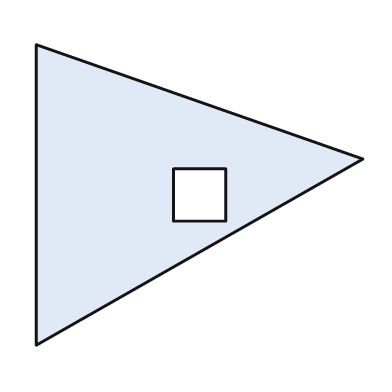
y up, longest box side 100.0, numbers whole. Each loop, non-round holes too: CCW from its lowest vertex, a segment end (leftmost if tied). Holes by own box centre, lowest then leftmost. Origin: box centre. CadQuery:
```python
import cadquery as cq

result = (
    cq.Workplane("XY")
    .moveTo(-50.0, -46.0)
    .lineTo(50.0, 11.0)
    .lineTo(-50.0, 46.0)
    .close()
    .moveTo(-8.0, -8.0)
    .lineTo(8.0, -8.0)
    .lineTo(8.0, 8.0)
    .lineTo(-8.0, 8.0)
    .close()
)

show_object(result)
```